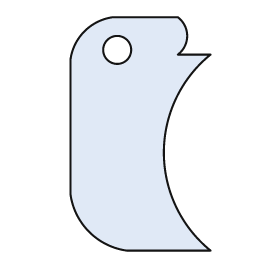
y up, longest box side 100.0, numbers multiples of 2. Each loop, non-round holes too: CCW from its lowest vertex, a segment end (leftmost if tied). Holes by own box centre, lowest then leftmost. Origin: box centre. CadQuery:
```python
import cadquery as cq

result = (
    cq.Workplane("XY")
    .moveTo(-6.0, -50.0)
    .lineTo(30.0, -50.0)
    .threePointArc((10.0, -8.0), (30.0, 34.0))
    .lineTo(16.0, 34.0)
    .threePointArc((20.0, 42.0), (16.0, 50.0))
    .lineTo(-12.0, 50.0)
    .threePointArc((-24.0, 44.0), (-30.0, 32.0))
    .lineTo(-30.0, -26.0)
    .threePointArc((-22.0, -42.0), (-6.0, -50.0))
    .close()
    .moveTo(-10.0, 36.0)
    .circle(6.0)
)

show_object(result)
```